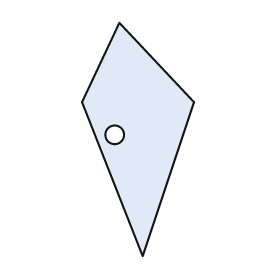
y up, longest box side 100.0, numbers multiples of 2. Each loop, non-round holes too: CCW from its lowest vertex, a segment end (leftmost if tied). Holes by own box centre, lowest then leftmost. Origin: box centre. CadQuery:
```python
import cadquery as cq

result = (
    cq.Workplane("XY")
    .moveTo(2.0, -50.0)
    .lineTo(24.0, 16.0)
    .lineTo(-8.0, 50.0)
    .lineTo(-24.0, 16.0)
    .close()
    .moveTo(-10.0, 2.0)
    .circle(4.0)
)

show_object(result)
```